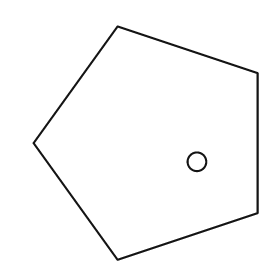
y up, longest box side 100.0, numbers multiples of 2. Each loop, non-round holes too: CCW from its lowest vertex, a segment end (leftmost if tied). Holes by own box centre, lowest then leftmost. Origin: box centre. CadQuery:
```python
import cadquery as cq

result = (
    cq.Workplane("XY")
    .moveTo(-12.0, -50.0)
    .lineTo(48.0, -30.0)
    .lineTo(48.0, 30.0)
    .lineTo(-12.0, 50.0)
    .lineTo(-48.0, 0.0)
    .close()
    .moveTo(22.0, -8.0)
    .circle(4.0)
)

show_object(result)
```